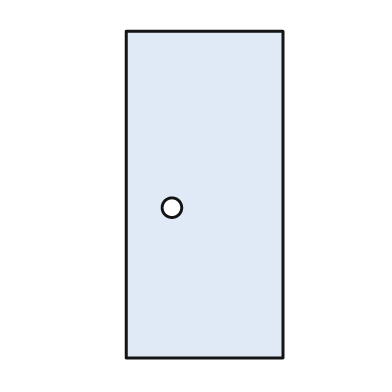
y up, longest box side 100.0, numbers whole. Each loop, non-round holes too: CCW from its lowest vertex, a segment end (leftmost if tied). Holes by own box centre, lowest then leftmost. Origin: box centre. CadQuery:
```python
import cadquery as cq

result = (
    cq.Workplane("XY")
    .moveTo(-24.0, -50.0)
    .lineTo(24.0, -50.0)
    .lineTo(24.0, 50.0)
    .lineTo(-24.0, 50.0)
    .close()
    .moveTo(-10.0, -4.0)
    .circle(3.0)
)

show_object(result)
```